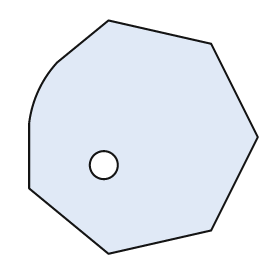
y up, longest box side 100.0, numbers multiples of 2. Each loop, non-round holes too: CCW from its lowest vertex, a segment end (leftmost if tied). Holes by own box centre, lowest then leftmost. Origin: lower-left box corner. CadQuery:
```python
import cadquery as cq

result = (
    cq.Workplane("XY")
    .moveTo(34.0, 0.0)
    .lineTo(78.0, 10.0)
    .lineTo(98.0, 50.0)
    .lineTo(78.0, 90.0)
    .lineTo(34.0, 100.0)
    .lineTo(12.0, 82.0)
    .threePointArc((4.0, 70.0), (0.0, 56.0))
    .lineTo(0.0, 28.0)
    .close()
    .moveTo(32.0, 38.0)
    .circle(6.0)
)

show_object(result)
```